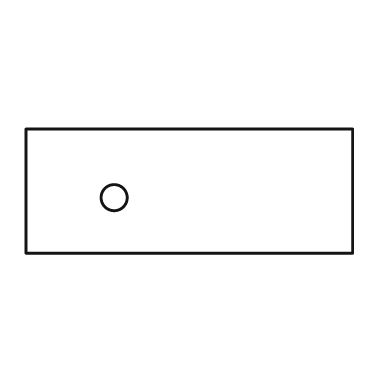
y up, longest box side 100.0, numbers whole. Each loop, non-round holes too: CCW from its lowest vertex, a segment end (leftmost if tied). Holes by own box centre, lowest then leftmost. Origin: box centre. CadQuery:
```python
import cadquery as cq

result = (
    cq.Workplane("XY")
    .moveTo(-50.0, -19.0)
    .lineTo(50.0, -19.0)
    .lineTo(50.0, 19.0)
    .lineTo(-50.0, 19.0)
    .close()
    .moveTo(-23.0, -2.0)
    .circle(4.0)
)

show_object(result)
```